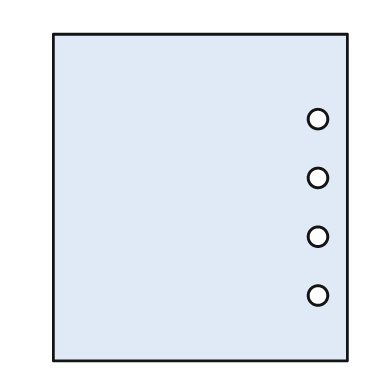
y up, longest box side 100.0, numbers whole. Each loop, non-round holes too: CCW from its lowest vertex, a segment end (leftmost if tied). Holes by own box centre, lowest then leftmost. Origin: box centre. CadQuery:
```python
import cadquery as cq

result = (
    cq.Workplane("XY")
    .moveTo(-45.0, -50.0)
    .lineTo(45.0, -50.0)
    .lineTo(45.0, 50.0)
    .lineTo(-45.0, 50.0)
    .close()
    .moveTo(36.0, -30.0)
    .circle(3.0)
    .moveTo(36.0, -12.0)
    .circle(3.0)
    .moveTo(36.0, 6.0)
    .circle(3.0)
    .moveTo(36.0, 24.0)
    .circle(3.0)
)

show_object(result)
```